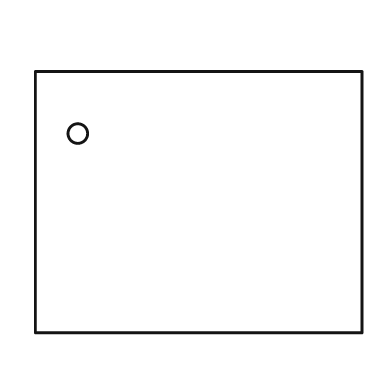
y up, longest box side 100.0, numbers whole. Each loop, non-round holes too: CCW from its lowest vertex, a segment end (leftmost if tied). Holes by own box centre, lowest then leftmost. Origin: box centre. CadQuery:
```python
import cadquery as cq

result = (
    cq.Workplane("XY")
    .moveTo(-50.0, -40.0)
    .lineTo(50.0, -40.0)
    .lineTo(50.0, 40.0)
    .lineTo(-50.0, 40.0)
    .close()
    .moveTo(-37.0, 21.0)
    .circle(3.0)
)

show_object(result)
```